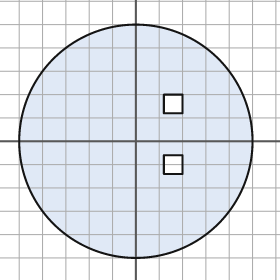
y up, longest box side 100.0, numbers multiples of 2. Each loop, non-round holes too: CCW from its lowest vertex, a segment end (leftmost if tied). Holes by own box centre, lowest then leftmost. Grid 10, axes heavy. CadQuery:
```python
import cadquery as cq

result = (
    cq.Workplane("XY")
    .moveTo(0.0, 0.0)
    .circle(50.0)
    .moveTo(12.0, -14.0)
    .lineTo(20.0, -14.0)
    .lineTo(20.0, -6.0)
    .lineTo(12.0, -6.0)
    .close()
    .moveTo(12.0, 12.0)
    .lineTo(20.0, 12.0)
    .lineTo(20.0, 20.0)
    .lineTo(12.0, 20.0)
    .close()
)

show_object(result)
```